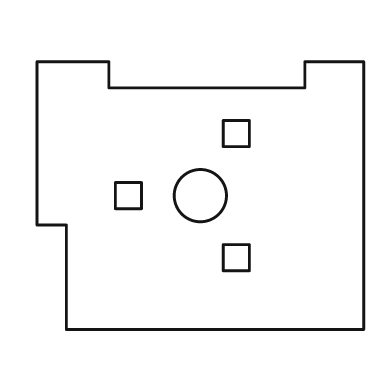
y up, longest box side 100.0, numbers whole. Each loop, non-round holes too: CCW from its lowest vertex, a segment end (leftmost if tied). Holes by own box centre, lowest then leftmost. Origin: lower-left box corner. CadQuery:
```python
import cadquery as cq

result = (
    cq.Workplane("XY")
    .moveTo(9.0, 0.0)
    .lineTo(100.0, 0.0)
    .lineTo(100.0, 82.0)
    .lineTo(82.0, 82.0)
    .lineTo(82.0, 74.0)
    .lineTo(22.0, 74.0)
    .lineTo(22.0, 82.0)
    .lineTo(0.0, 82.0)
    .lineTo(0.0, 32.0)
    .lineTo(9.0, 32.0)
    .close()
    .moveTo(57.0, 18.0)
    .lineTo(65.0, 18.0)
    .lineTo(65.0, 26.0)
    .lineTo(57.0, 26.0)
    .close()
    .moveTo(24.0, 37.0)
    .lineTo(32.0, 37.0)
    .lineTo(32.0, 45.0)
    .lineTo(24.0, 45.0)
    .close()
    .moveTo(50.0, 41.0)
    .circle(8.0)
    .moveTo(57.0, 56.0)
    .lineTo(65.0, 56.0)
    .lineTo(65.0, 64.0)
    .lineTo(57.0, 64.0)
    .close()
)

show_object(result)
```